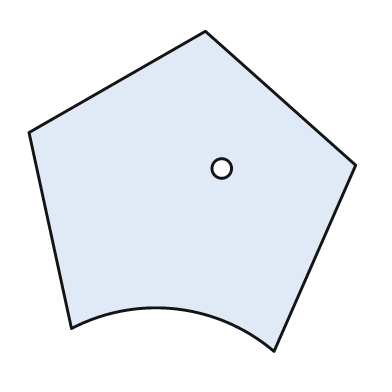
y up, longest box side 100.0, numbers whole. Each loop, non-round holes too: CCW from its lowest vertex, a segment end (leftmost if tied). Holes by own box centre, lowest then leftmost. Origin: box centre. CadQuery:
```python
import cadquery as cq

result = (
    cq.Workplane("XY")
    .moveTo(25.0, -49.0)
    .lineTo(50.0, 8.0)
    .lineTo(4.0, 49.0)
    .lineTo(-50.0, 18.0)
    .lineTo(-37.0, -42.0)
    .threePointArc((-5.0, -36.0), (25.0, -49.0))
    .close()
    .moveTo(9.0, 7.0)
    .circle(3.0)
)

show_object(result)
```